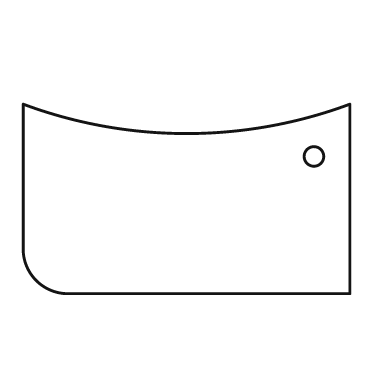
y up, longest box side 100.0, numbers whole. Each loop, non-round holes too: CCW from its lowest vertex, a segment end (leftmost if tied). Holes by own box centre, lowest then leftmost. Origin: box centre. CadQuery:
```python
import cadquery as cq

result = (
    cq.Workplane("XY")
    .moveTo(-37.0, -29.0)
    .lineTo(50.0, -29.0)
    .lineTo(50.0, 29.0)
    .threePointArc((0.0, 20.0), (-50.0, 29.0))
    .lineTo(-50.0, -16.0)
    .threePointArc((-46.0, -25.0), (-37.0, -29.0))
    .close()
    .moveTo(39.0, 13.0)
    .circle(3.0)
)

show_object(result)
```